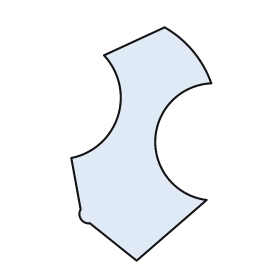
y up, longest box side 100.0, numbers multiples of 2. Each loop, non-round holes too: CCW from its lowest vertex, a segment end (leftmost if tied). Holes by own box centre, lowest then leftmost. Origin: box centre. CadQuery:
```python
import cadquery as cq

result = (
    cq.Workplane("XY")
    .moveTo(-2.0, -50.0)
    .lineTo(28.0, -24.0)
    .threePointArc((6.0, 2.0), (30.0, 26.0))
    .threePointArc((22.0, 40.0), (10.0, 50.0))
    .lineTo(-16.0, 38.0)
    .threePointArc((-10.0, 12.0), (-30.0, -6.0))
    .lineTo(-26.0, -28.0)
    .threePointArc((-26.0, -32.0), (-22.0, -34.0))
    .close()
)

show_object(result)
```